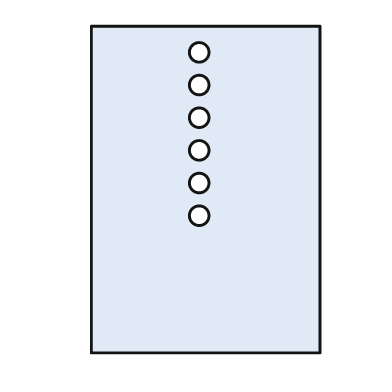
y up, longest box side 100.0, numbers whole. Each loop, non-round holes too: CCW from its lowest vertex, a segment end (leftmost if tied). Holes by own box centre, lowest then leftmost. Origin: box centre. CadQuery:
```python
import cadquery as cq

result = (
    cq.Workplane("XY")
    .moveTo(-35.0, -50.0)
    .lineTo(35.0, -50.0)
    .lineTo(35.0, 50.0)
    .lineTo(-35.0, 50.0)
    .close()
    .moveTo(-2.0, -8.0)
    .circle(3.0)
    .moveTo(-2.0, 2.0)
    .circle(3.0)
    .moveTo(-2.0, 12.0)
    .circle(3.0)
    .moveTo(-2.0, 22.0)
    .circle(3.0)
    .moveTo(-2.0, 32.0)
    .circle(3.0)
    .moveTo(-2.0, 42.0)
    .circle(3.0)
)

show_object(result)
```